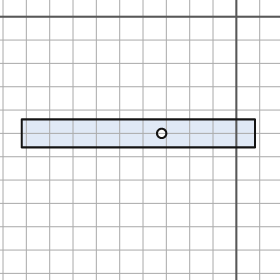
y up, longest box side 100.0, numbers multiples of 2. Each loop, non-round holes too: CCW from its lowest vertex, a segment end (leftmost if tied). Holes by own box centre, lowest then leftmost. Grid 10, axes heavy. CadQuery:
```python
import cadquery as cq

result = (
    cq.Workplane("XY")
    .moveTo(-92.0, -56.0)
    .lineTo(8.0, -56.0)
    .lineTo(8.0, -44.0)
    .lineTo(-92.0, -44.0)
    .close()
    .moveTo(-32.0, -50.0)
    .circle(2.0)
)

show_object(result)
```